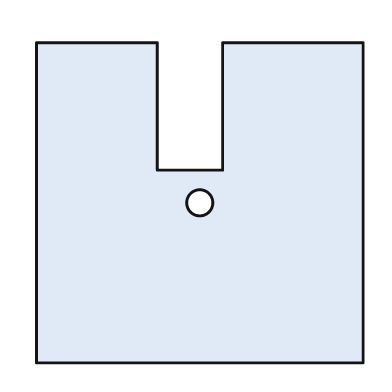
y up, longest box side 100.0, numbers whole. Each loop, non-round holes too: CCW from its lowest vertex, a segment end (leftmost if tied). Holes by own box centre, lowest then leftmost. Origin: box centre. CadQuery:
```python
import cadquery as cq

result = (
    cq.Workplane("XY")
    .moveTo(-50.0, -49.0)
    .lineTo(50.0, -49.0)
    .lineTo(50.0, 49.0)
    .lineTo(7.0, 49.0)
    .lineTo(7.0, 10.0)
    .lineTo(-13.0, 10.0)
    .lineTo(-13.0, 49.0)
    .lineTo(-50.0, 49.0)
    .close()
    .moveTo(0.0, 0.0)
    .circle(4.0)
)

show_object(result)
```